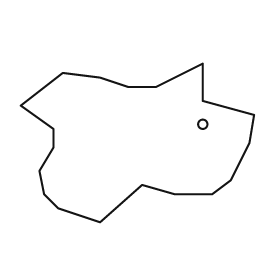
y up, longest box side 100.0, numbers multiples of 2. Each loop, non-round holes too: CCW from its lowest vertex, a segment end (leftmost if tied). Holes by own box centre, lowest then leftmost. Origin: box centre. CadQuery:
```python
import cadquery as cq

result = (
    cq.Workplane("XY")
    .moveTo(-16.0, -34.0)
    .lineTo(2.0, -18.0)
    .lineTo(16.0, -22.0)
    .lineTo(32.0, -22.0)
    .lineTo(40.0, -16.0)
    .lineTo(48.0, 0.0)
    .lineTo(50.0, 12.0)
    .lineTo(28.0, 18.0)
    .lineTo(28.0, 34.0)
    .lineTo(8.0, 24.0)
    .lineTo(-4.0, 24.0)
    .lineTo(-16.0, 28.0)
    .lineTo(-32.0, 30.0)
    .lineTo(-50.0, 16.0)
    .lineTo(-36.0, 6.0)
    .lineTo(-36.0, -2.0)
    .lineTo(-42.0, -12.0)
    .lineTo(-40.0, -22.0)
    .lineTo(-34.0, -28.0)
    .close()
    .moveTo(28.0, 8.0)
    .circle(2.0)
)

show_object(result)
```